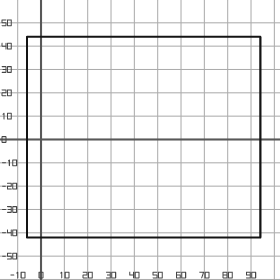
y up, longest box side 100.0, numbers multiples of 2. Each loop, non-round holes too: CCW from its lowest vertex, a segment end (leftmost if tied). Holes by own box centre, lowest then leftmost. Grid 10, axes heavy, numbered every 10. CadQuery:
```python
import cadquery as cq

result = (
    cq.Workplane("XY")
    .moveTo(-6.0, -42.0)
    .lineTo(94.0, -42.0)
    .lineTo(94.0, 44.0)
    .lineTo(-6.0, 44.0)
    .close()
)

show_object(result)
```